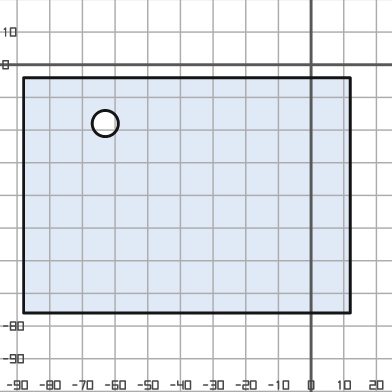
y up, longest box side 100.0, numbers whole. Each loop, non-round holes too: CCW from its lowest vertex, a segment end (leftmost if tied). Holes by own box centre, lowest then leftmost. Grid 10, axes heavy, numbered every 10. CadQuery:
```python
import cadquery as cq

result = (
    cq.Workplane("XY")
    .moveTo(-88.0, -76.0)
    .lineTo(12.0, -76.0)
    .lineTo(12.0, -4.0)
    .lineTo(-88.0, -4.0)
    .close()
    .moveTo(-63.0, -18.0)
    .circle(4.0)
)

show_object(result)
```